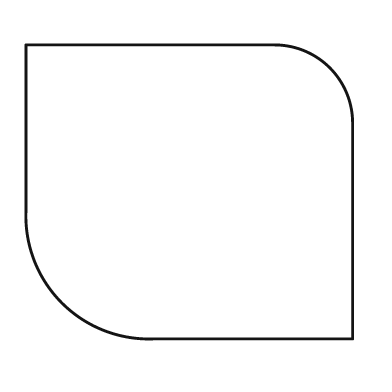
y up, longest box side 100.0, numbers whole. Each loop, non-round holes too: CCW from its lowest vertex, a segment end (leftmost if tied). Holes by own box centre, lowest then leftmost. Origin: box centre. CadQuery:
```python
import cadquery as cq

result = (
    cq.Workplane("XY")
    .moveTo(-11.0, -45.0)
    .lineTo(50.0, -45.0)
    .lineTo(50.0, 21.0)
    .threePointArc((43.0, 38.0), (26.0, 45.0))
    .lineTo(-50.0, 45.0)
    .lineTo(-50.0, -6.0)
    .threePointArc((-39.0, -34.0), (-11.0, -45.0))
    .close()
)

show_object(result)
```